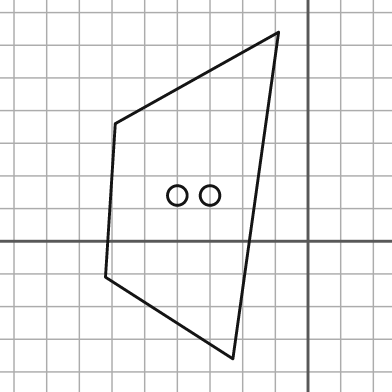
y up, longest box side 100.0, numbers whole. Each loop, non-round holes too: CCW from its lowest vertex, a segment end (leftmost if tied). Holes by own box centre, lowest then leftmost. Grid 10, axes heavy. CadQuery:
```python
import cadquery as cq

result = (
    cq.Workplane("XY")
    .moveTo(-23.0, -36.0)
    .lineTo(-9.0, 64.0)
    .lineTo(-59.0, 36.0)
    .lineTo(-62.0, -11.0)
    .close()
    .moveTo(-40.0, 14.0)
    .circle(3.0)
    .moveTo(-30.0, 14.0)
    .circle(3.0)
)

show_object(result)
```